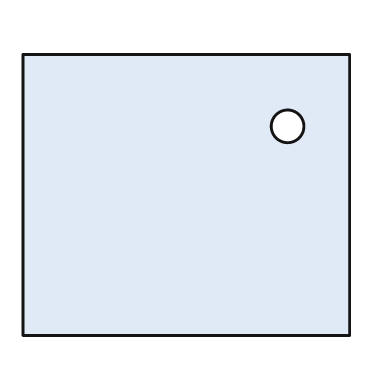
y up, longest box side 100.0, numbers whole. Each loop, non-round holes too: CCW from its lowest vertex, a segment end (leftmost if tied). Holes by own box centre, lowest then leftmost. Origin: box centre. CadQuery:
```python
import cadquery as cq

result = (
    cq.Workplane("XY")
    .moveTo(-50.0, -43.0)
    .lineTo(50.0, -43.0)
    .lineTo(50.0, 43.0)
    .lineTo(-50.0, 43.0)
    .close()
    .moveTo(31.0, 21.0)
    .circle(5.0)
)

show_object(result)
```